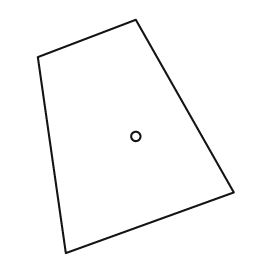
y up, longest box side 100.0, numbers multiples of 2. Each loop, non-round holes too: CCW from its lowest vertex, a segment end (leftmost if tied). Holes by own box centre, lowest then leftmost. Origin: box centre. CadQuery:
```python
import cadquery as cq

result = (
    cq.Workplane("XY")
    .moveTo(-30.0, -50.0)
    .lineTo(42.0, -24.0)
    .lineTo(0.0, 50.0)
    .lineTo(-42.0, 34.0)
    .close()
    .moveTo(0.0, 0.0)
    .circle(2.0)
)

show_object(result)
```